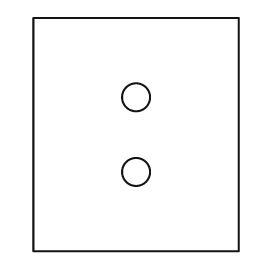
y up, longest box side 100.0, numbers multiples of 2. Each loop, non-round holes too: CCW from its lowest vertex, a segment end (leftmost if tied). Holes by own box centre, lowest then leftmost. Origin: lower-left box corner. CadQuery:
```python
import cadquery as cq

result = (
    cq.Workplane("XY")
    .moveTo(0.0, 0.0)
    .lineTo(88.0, 0.0)
    .lineTo(88.0, 100.0)
    .lineTo(0.0, 100.0)
    .close()
    .moveTo(44.0, 34.0)
    .circle(6.0)
    .moveTo(44.0, 66.0)
    .circle(6.0)
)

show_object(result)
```